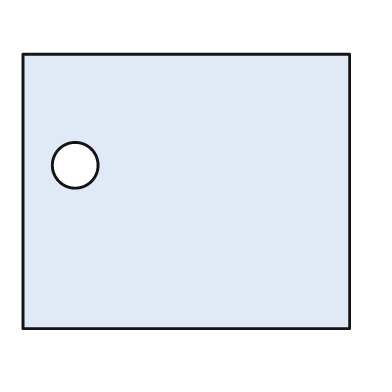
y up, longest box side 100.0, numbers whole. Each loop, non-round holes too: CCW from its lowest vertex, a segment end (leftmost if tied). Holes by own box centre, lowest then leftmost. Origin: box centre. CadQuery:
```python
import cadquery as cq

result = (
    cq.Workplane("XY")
    .moveTo(-50.0, -42.0)
    .lineTo(50.0, -42.0)
    .lineTo(50.0, 42.0)
    .lineTo(-50.0, 42.0)
    .close()
    .moveTo(-34.0, 8.0)
    .circle(7.0)
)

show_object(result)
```